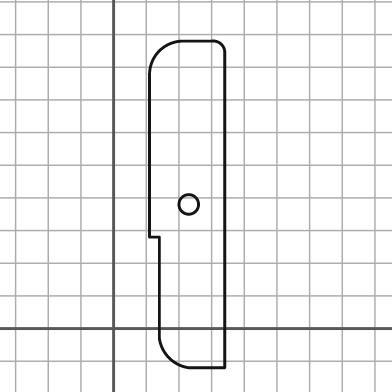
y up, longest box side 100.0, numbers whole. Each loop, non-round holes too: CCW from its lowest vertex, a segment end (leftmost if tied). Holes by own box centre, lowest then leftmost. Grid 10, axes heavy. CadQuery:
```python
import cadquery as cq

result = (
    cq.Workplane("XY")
    .moveTo(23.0, -12.0)
    .lineTo(34.0, -12.0)
    .lineTo(34.0, 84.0)
    .threePointArc((33.0, 87.0), (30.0, 88.0))
    .lineTo(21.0, 88.0)
    .threePointArc((14.0, 85.0), (11.0, 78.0))
    .lineTo(11.0, 28.0)
    .lineTo(14.0, 28.0)
    .lineTo(14.0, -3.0)
    .threePointArc((17.0, -9.0), (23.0, -12.0))
    .close()
    .moveTo(23.0, 38.0)
    .circle(3.0)
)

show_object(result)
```